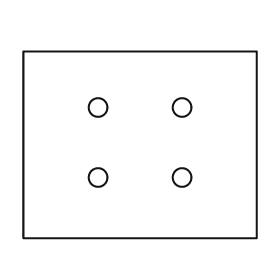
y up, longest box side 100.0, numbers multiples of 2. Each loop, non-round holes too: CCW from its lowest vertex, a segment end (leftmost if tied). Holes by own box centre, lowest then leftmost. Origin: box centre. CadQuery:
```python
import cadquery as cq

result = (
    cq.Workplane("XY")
    .moveTo(-50.0, -40.0)
    .lineTo(50.0, -40.0)
    .lineTo(50.0, 40.0)
    .lineTo(-50.0, 40.0)
    .close()
    .moveTo(-18.0, -14.0)
    .circle(4.0)
    .moveTo(18.0, -14.0)
    .circle(4.0)
    .moveTo(-18.0, 16.0)
    .circle(4.0)
    .moveTo(18.0, 16.0)
    .circle(4.0)
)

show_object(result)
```